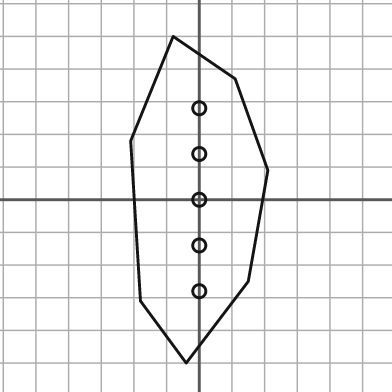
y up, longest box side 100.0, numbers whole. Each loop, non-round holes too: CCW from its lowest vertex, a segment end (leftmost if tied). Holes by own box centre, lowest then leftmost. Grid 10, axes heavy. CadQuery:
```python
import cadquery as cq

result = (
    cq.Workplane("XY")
    .moveTo(-4.0, -50.0)
    .lineTo(15.0, -25.0)
    .lineTo(21.0, 9.0)
    .lineTo(11.0, 37.0)
    .lineTo(-8.0, 50.0)
    .lineTo(-21.0, 18.0)
    .lineTo(-18.0, -31.0)
    .close()
    .moveTo(0.0, -28.0)
    .circle(2.0)
    .moveTo(0.0, -14.0)
    .circle(2.0)
    .moveTo(0.0, 0.0)
    .circle(2.0)
    .moveTo(0.0, 14.0)
    .circle(2.0)
    .moveTo(0.0, 28.0)
    .circle(2.0)
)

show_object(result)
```